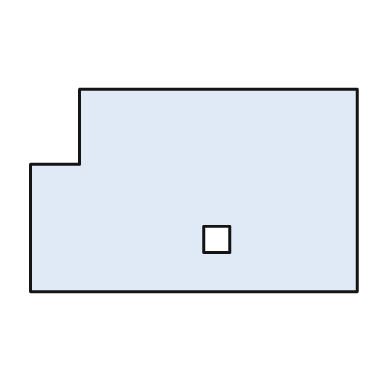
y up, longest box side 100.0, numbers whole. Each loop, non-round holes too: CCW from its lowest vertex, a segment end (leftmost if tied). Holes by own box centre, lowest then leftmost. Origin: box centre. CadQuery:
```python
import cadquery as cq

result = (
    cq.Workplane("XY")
    .moveTo(-50.0, -31.0)
    .lineTo(50.0, -31.0)
    .lineTo(50.0, 31.0)
    .lineTo(-35.0, 31.0)
    .lineTo(-35.0, 8.0)
    .lineTo(-50.0, 8.0)
    .close()
    .moveTo(3.0, -19.0)
    .lineTo(11.0, -19.0)
    .lineTo(11.0, -11.0)
    .lineTo(3.0, -11.0)
    .close()
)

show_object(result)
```